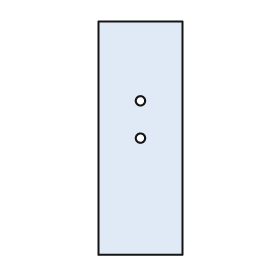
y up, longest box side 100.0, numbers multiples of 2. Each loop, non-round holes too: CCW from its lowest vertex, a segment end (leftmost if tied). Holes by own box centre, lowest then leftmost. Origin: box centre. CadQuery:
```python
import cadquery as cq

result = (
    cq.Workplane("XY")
    .moveTo(-18.0, -50.0)
    .lineTo(18.0, -50.0)
    .lineTo(18.0, 50.0)
    .lineTo(-18.0, 50.0)
    .close()
    .moveTo(0.0, 0.0)
    .circle(2.0)
    .moveTo(0.0, 16.0)
    .circle(2.0)
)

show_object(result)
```